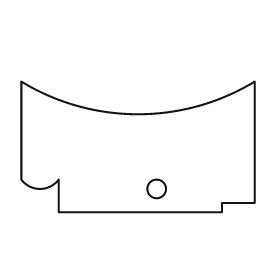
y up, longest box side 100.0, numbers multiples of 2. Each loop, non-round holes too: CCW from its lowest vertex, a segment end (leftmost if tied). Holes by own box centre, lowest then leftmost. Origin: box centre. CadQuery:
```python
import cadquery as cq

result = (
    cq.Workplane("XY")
    .moveTo(-34.0, -28.0)
    .lineTo(36.0, -28.0)
    .lineTo(36.0, -24.0)
    .lineTo(50.0, -24.0)
    .lineTo(50.0, 28.0)
    .threePointArc((0.0, 14.0), (-50.0, 28.0))
    .lineTo(-50.0, -14.0)
    .threePointArc((-42.0, -18.0), (-34.0, -14.0))
    .close()
    .moveTo(8.0, -18.0)
    .circle(4.0)
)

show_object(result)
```